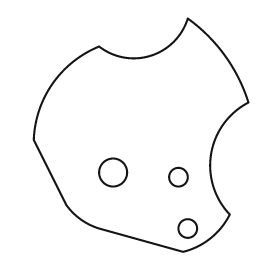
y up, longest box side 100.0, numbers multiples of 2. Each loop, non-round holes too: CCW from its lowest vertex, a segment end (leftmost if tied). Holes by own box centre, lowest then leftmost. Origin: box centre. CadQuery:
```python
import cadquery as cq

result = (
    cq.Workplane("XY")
    .moveTo(18.0, -50.0)
    .threePointArc((30.0, -44.0), (38.0, -34.0))
    .threePointArc((30.0, -8.0), (46.0, 14.0))
    .threePointArc((36.0, 34.0), (20.0, 50.0))
    .threePointArc((4.0, 34.0), (-18.0, 38.0))
    .threePointArc((-38.0, 22.0), (-46.0, -2.0))
    .lineTo(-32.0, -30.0)
    .threePointArc((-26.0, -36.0), (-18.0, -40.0))
    .close()
    .moveTo(20.0, -40.0)
    .circle(4.0)
    .moveTo(16.0, -18.0)
    .circle(4.0)
    .moveTo(-12.0, -16.0)
    .circle(6.0)
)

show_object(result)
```